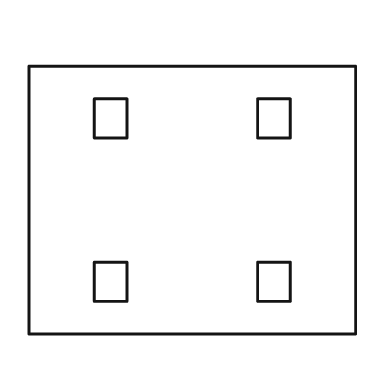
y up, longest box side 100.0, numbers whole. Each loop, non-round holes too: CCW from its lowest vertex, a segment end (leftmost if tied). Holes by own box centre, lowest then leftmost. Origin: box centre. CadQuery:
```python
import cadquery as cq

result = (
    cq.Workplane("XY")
    .moveTo(-50.0, -41.0)
    .lineTo(50.0, -41.0)
    .lineTo(50.0, 41.0)
    .lineTo(-50.0, 41.0)
    .close()
    .moveTo(-30.0, -31.0)
    .lineTo(-20.0, -31.0)
    .lineTo(-20.0, -19.0)
    .lineTo(-30.0, -19.0)
    .close()
    .moveTo(20.0, -31.0)
    .lineTo(30.0, -31.0)
    .lineTo(30.0, -19.0)
    .lineTo(20.0, -19.0)
    .close()
    .moveTo(-30.0, 19.0)
    .lineTo(-20.0, 19.0)
    .lineTo(-20.0, 31.0)
    .lineTo(-30.0, 31.0)
    .close()
    .moveTo(20.0, 19.0)
    .lineTo(30.0, 19.0)
    .lineTo(30.0, 31.0)
    .lineTo(20.0, 31.0)
    .close()
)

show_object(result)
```